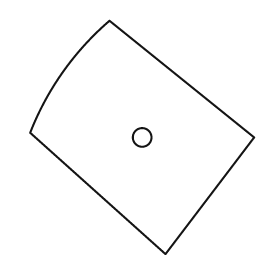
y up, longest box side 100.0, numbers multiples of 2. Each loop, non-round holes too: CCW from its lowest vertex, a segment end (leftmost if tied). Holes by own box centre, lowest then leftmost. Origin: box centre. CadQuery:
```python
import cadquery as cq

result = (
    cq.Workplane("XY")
    .moveTo(10.0, -50.0)
    .lineTo(48.0, 0.0)
    .lineTo(-14.0, 50.0)
    .threePointArc((-34.0, 28.0), (-48.0, 2.0))
    .close()
    .moveTo(0.0, 0.0)
    .circle(4.0)
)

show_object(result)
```